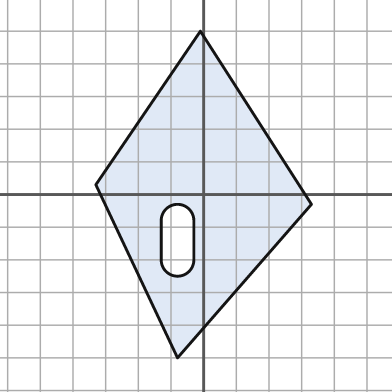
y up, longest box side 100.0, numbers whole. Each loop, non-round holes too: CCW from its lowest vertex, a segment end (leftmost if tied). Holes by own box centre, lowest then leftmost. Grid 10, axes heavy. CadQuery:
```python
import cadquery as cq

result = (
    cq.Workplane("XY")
    .moveTo(-8.0, -50.0)
    .lineTo(33.0, -3.0)
    .lineTo(-1.0, 50.0)
    .lineTo(-33.0, 3.0)
    .close()
    .moveTo(-13.0, -20.0)
    .threePointArc((-8.0, -25.0), (-3.0, -20.0))
    .lineTo(-3.0, -8.0)
    .threePointArc((-8.0, -3.0), (-13.0, -8.0))
    .close()
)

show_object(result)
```